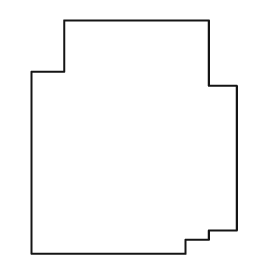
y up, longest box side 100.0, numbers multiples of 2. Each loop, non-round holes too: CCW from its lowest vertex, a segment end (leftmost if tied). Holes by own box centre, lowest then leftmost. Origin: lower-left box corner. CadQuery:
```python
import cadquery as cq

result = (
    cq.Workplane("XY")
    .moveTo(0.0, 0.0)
    .lineTo(66.0, 0.0)
    .lineTo(66.0, 6.0)
    .lineTo(76.0, 6.0)
    .lineTo(76.0, 10.0)
    .lineTo(88.0, 10.0)
    .lineTo(88.0, 72.0)
    .lineTo(76.0, 72.0)
    .lineTo(76.0, 100.0)
    .lineTo(14.0, 100.0)
    .lineTo(14.0, 78.0)
    .lineTo(0.0, 78.0)
    .close()
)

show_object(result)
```